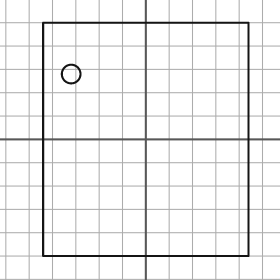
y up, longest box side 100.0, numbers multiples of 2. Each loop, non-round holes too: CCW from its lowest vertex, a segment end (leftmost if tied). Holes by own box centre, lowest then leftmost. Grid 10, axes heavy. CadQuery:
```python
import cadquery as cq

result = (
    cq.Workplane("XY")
    .moveTo(-44.0, -50.0)
    .lineTo(44.0, -50.0)
    .lineTo(44.0, 50.0)
    .lineTo(-44.0, 50.0)
    .close()
    .moveTo(-32.0, 28.0)
    .circle(4.0)
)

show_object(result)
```